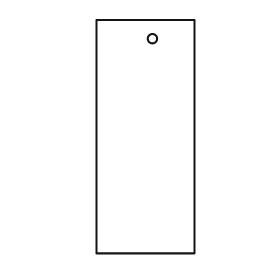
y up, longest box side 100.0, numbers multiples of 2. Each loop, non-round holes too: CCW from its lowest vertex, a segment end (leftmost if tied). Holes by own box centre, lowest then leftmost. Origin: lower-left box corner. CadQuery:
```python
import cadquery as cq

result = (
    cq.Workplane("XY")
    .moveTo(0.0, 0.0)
    .lineTo(42.0, 0.0)
    .lineTo(42.0, 100.0)
    .lineTo(0.0, 100.0)
    .close()
    .moveTo(24.0, 92.0)
    .circle(2.0)
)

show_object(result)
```